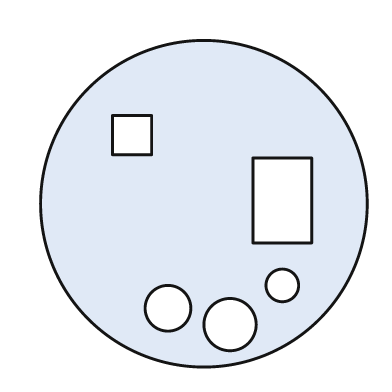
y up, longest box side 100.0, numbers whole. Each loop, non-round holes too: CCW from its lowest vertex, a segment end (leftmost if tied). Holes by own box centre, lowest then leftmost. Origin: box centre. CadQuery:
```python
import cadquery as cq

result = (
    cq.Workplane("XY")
    .moveTo(0.0, 0.0)
    .circle(50.0)
    .moveTo(8.0, -37.0)
    .circle(8.0)
    .moveTo(-11.0, -32.0)
    .circle(7.0)
    .moveTo(24.0, -25.0)
    .circle(5.0)
    .moveTo(15.0, -12.0)
    .lineTo(33.0, -12.0)
    .lineTo(33.0, 14.0)
    .lineTo(15.0, 14.0)
    .close()
    .moveTo(-28.0, 15.0)
    .lineTo(-16.0, 15.0)
    .lineTo(-16.0, 27.0)
    .lineTo(-28.0, 27.0)
    .close()
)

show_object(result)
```